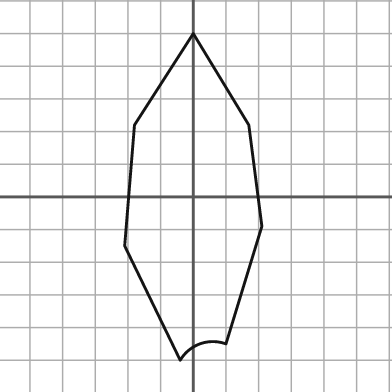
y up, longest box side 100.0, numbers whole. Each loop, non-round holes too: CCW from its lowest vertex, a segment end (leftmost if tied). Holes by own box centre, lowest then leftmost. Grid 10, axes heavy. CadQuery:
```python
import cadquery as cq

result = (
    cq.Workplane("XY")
    .moveTo(-4.0, -50.0)
    .threePointArc((2.0, -45.0), (10.0, -45.0))
    .lineTo(21.0, -9.0)
    .lineTo(17.0, 22.0)
    .lineTo(0.0, 50.0)
    .lineTo(-18.0, 22.0)
    .lineTo(-21.0, -15.0)
    .close()
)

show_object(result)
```